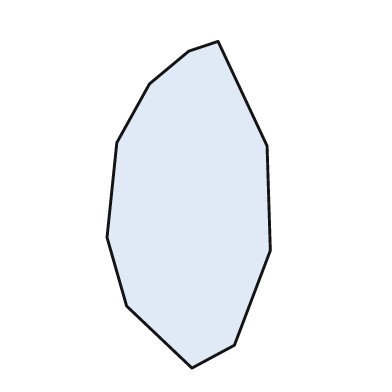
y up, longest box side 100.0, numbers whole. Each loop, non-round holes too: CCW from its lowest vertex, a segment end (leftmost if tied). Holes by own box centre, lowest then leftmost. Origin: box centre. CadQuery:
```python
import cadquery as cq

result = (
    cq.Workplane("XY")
    .moveTo(1.0, -50.0)
    .lineTo(14.0, -43.0)
    .lineTo(25.0, -14.0)
    .lineTo(24.0, 18.0)
    .lineTo(9.0, 50.0)
    .lineTo(0.0, 47.0)
    .lineTo(-12.0, 37.0)
    .lineTo(-22.0, 19.0)
    .lineTo(-25.0, -10.0)
    .lineTo(-19.0, -31.0)
    .close()
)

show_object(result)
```